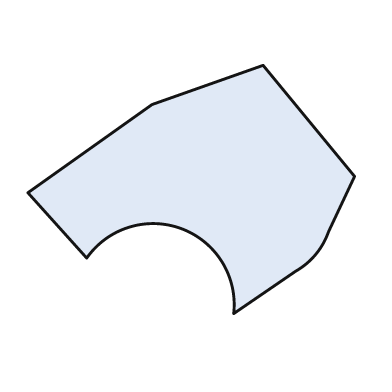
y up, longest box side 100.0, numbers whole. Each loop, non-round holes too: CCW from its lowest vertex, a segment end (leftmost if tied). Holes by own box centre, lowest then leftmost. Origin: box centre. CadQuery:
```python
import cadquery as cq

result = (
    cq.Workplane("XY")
    .moveTo(13.0, -38.0)
    .lineTo(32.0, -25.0)
    .threePointArc((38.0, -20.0), (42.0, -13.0))
    .lineTo(50.0, 4.0)
    .lineTo(22.0, 38.0)
    .lineTo(-12.0, 26.0)
    .lineTo(-50.0, -1.0)
    .lineTo(-32.0, -21.0)
    .threePointArc((-3.0, -12.0), (13.0, -38.0))
    .close()
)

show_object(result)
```